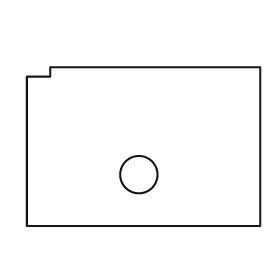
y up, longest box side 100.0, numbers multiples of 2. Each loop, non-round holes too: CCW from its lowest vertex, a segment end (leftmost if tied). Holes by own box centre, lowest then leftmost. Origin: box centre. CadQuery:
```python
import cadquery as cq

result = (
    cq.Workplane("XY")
    .moveTo(-50.0, -34.0)
    .lineTo(50.0, -34.0)
    .lineTo(50.0, 34.0)
    .lineTo(-40.0, 34.0)
    .lineTo(-40.0, 30.0)
    .lineTo(-50.0, 30.0)
    .close()
    .moveTo(-2.0, -12.0)
    .circle(8.0)
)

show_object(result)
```